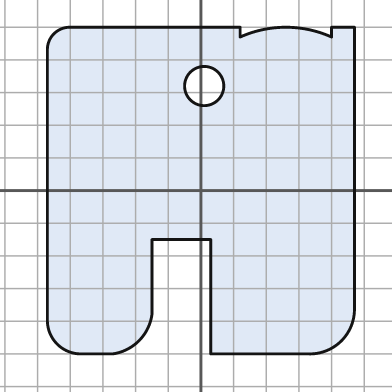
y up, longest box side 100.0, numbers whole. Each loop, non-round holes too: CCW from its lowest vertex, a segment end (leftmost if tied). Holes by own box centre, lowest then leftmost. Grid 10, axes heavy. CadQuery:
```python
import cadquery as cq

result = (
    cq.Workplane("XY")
    .moveTo(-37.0, -50.0)
    .lineTo(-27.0, -50.0)
    .threePointArc((-19.0, -46.0), (-15.0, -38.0))
    .lineTo(-15.0, -15.0)
    .lineTo(3.0, -15.0)
    .lineTo(3.0, -50.0)
    .lineTo(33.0, -50.0)
    .threePointArc((43.0, -46.0), (47.0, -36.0))
    .lineTo(47.0, 50.0)
    .lineTo(40.0, 50.0)
    .lineTo(40.0, 47.0)
    .threePointArc((26.0, 50.0), (12.0, 47.0))
    .lineTo(12.0, 50.0)
    .lineTo(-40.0, 50.0)
    .threePointArc((-45.0, 48.0), (-47.0, 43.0))
    .lineTo(-47.0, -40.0)
    .threePointArc((-44.0, -47.0), (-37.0, -50.0))
    .close()
    .moveTo(1.0, 32.0)
    .circle(6.0)
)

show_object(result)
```